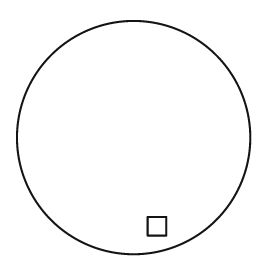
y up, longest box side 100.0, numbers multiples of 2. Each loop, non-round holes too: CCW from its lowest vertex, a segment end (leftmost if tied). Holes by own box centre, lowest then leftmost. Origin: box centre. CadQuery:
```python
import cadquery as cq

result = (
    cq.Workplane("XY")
    .moveTo(0.0, 0.0)
    .circle(50.0)
    .moveTo(6.0, -42.0)
    .lineTo(14.0, -42.0)
    .lineTo(14.0, -34.0)
    .lineTo(6.0, -34.0)
    .close()
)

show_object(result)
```